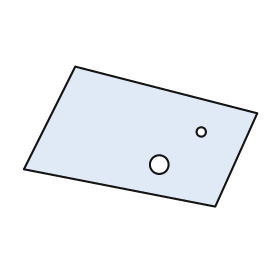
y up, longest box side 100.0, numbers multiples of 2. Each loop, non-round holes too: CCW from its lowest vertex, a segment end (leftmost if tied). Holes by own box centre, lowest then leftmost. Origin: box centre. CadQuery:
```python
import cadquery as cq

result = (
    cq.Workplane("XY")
    .moveTo(32.0, -30.0)
    .lineTo(50.0, 10.0)
    .lineTo(-28.0, 30.0)
    .lineTo(-50.0, -14.0)
    .close()
    .moveTo(8.0, -12.0)
    .circle(4.0)
    .moveTo(26.0, 2.0)
    .circle(2.0)
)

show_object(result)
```